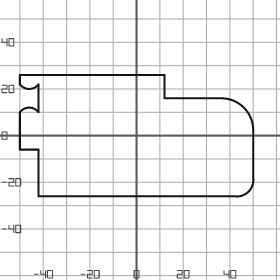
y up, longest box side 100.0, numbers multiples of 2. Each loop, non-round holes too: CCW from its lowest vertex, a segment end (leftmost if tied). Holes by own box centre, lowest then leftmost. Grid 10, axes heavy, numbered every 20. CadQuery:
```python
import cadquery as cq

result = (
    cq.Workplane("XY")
    .moveTo(-42.0, -26.0)
    .lineTo(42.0, -26.0)
    .threePointArc((48.0, -24.0), (50.0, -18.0))
    .lineTo(50.0, 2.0)
    .threePointArc((46.0, 12.0), (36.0, 16.0))
    .lineTo(12.0, 16.0)
    .lineTo(12.0, 26.0)
    .lineTo(-50.0, 26.0)
    .lineTo(-50.0, 22.0)
    .threePointArc((-46.0, 20.0), (-42.0, 22.0))
    .lineTo(-42.0, 10.0)
    .threePointArc((-46.0, 12.0), (-50.0, 10.0))
    .lineTo(-50.0, -6.0)
    .lineTo(-42.0, -6.0)
    .close()
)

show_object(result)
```